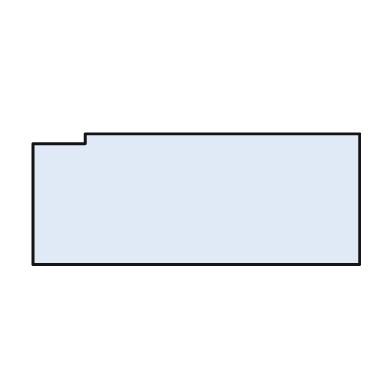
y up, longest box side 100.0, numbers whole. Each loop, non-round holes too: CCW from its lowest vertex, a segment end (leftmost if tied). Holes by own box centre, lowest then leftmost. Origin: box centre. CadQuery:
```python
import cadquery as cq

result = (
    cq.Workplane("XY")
    .moveTo(-50.0, -20.0)
    .lineTo(50.0, -20.0)
    .lineTo(50.0, 20.0)
    .lineTo(-34.0, 20.0)
    .lineTo(-34.0, 17.0)
    .lineTo(-50.0, 17.0)
    .close()
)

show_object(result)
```